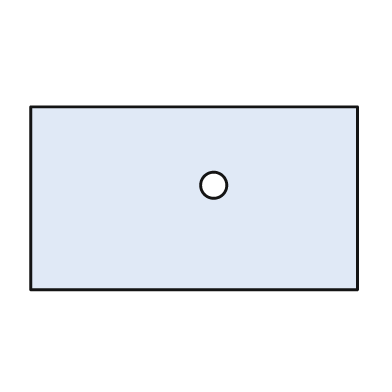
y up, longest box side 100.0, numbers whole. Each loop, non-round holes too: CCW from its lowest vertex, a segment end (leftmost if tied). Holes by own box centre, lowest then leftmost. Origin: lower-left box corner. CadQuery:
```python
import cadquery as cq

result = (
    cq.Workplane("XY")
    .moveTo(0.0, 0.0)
    .lineTo(100.0, 0.0)
    .lineTo(100.0, 56.0)
    .lineTo(0.0, 56.0)
    .close()
    .moveTo(56.0, 32.0)
    .circle(4.0)
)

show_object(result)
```